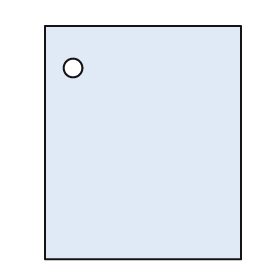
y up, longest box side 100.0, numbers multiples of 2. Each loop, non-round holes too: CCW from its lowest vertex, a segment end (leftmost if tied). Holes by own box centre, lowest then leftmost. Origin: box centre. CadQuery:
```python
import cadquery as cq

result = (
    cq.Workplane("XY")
    .moveTo(-42.0, -50.0)
    .lineTo(42.0, -50.0)
    .lineTo(42.0, 50.0)
    .lineTo(-42.0, 50.0)
    .close()
    .moveTo(-30.0, 32.0)
    .circle(4.0)
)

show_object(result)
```